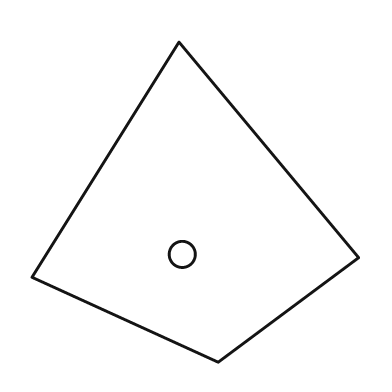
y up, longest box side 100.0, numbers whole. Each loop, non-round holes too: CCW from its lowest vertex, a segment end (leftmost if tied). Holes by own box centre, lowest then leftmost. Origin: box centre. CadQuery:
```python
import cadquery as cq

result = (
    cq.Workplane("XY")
    .moveTo(7.0, -49.0)
    .lineTo(50.0, -17.0)
    .lineTo(-5.0, 49.0)
    .lineTo(-50.0, -23.0)
    .close()
    .moveTo(-4.0, -16.0)
    .circle(4.0)
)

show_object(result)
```